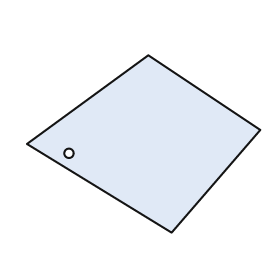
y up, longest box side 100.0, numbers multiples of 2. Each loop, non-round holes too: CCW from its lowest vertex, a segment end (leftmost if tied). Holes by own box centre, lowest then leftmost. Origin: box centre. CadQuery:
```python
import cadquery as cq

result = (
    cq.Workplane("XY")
    .moveTo(12.0, -38.0)
    .lineTo(50.0, 6.0)
    .lineTo(2.0, 38.0)
    .lineTo(-50.0, 0.0)
    .close()
    .moveTo(-32.0, -4.0)
    .circle(2.0)
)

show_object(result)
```